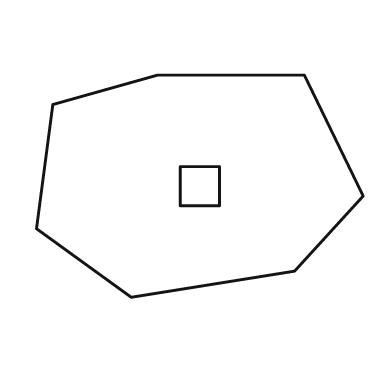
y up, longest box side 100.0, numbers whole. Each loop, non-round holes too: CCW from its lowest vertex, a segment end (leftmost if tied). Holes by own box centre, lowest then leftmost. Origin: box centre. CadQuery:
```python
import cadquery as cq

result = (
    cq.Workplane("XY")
    .moveTo(-21.0, -34.0)
    .lineTo(29.0, -26.0)
    .lineTo(50.0, -3.0)
    .lineTo(32.0, 34.0)
    .lineTo(-13.0, 34.0)
    .lineTo(-45.0, 25.0)
    .lineTo(-50.0, -13.0)
    .close()
    .moveTo(-6.0, -6.0)
    .lineTo(6.0, -6.0)
    .lineTo(6.0, 6.0)
    .lineTo(-6.0, 6.0)
    .close()
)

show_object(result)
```